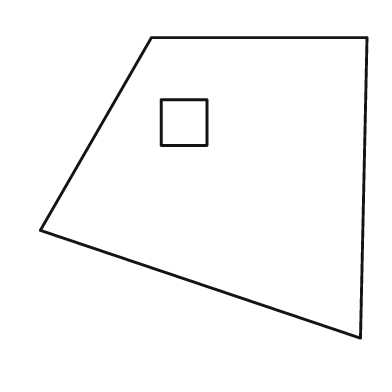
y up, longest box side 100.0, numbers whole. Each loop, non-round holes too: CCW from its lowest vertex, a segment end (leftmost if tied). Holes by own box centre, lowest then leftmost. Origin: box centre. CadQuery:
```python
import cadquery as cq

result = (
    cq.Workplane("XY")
    .moveTo(48.0, -46.0)
    .lineTo(50.0, 46.0)
    .lineTo(-16.0, 46.0)
    .lineTo(-50.0, -13.0)
    .close()
    .moveTo(-13.0, 13.0)
    .lineTo(1.0, 13.0)
    .lineTo(1.0, 27.0)
    .lineTo(-13.0, 27.0)
    .close()
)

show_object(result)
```